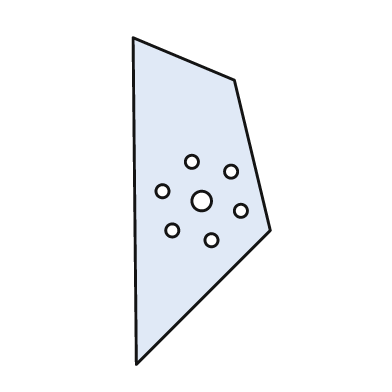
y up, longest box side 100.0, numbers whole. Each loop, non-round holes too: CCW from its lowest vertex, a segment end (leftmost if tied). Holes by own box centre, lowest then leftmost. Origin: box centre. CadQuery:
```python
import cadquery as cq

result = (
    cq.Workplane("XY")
    .moveTo(-20.0, -50.0)
    .lineTo(21.0, -9.0)
    .lineTo(10.0, 37.0)
    .lineTo(-21.0, 50.0)
    .close()
    .moveTo(3.0, -12.0)
    .circle(2.0)
    .moveTo(-9.0, -9.0)
    .circle(2.0)
    .moveTo(12.0, -3.0)
    .circle(2.0)
    .moveTo(0.0, 0.0)
    .circle(3.0)
    .moveTo(-12.0, 3.0)
    .circle(2.0)
    .moveTo(9.0, 9.0)
    .circle(2.0)
    .moveTo(-3.0, 12.0)
    .circle(2.0)
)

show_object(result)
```